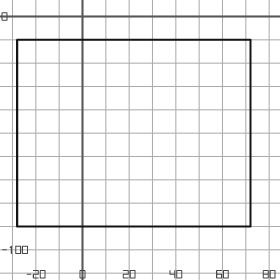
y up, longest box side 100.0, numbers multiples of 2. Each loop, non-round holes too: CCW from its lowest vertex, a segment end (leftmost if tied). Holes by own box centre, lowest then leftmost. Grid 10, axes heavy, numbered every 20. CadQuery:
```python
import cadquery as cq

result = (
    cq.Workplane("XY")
    .moveTo(-28.0, -90.0)
    .lineTo(72.0, -90.0)
    .lineTo(72.0, -10.0)
    .lineTo(-28.0, -10.0)
    .close()
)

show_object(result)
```